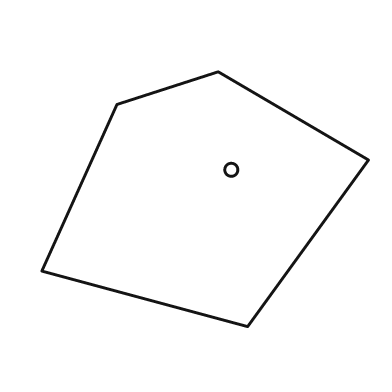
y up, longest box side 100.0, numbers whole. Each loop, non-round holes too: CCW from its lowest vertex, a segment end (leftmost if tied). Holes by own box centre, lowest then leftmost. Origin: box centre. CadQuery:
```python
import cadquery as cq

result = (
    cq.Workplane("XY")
    .moveTo(13.0, -39.0)
    .lineTo(50.0, 12.0)
    .lineTo(4.0, 39.0)
    .lineTo(-27.0, 29.0)
    .lineTo(-50.0, -22.0)
    .close()
    .moveTo(8.0, 9.0)
    .circle(2.0)
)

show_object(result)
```